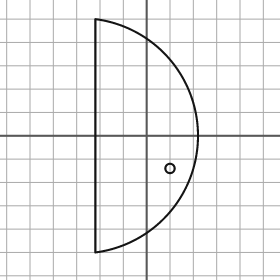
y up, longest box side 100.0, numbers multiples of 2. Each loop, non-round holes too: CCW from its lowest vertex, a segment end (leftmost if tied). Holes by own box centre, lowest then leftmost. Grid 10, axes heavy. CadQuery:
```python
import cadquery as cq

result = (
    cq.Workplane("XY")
    .moveTo(-22.0, -50.0)
    .threePointArc((22.0, 0.0), (-22.0, 50.0))
    .close()
    .moveTo(10.0, -14.0)
    .circle(2.0)
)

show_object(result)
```